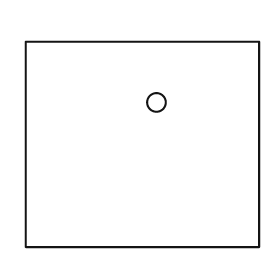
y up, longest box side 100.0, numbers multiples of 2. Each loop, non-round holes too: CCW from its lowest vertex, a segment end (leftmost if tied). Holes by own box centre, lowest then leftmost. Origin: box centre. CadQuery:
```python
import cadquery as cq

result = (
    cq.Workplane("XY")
    .moveTo(-50.0, -44.0)
    .lineTo(50.0, -44.0)
    .lineTo(50.0, 44.0)
    .lineTo(-50.0, 44.0)
    .close()
    .moveTo(6.0, 18.0)
    .circle(4.0)
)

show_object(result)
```